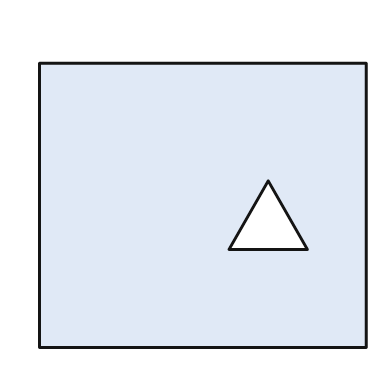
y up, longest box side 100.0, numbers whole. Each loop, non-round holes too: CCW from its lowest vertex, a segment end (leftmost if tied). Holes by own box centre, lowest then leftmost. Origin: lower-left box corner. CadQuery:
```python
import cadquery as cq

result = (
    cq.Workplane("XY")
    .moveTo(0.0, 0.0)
    .lineTo(100.0, 0.0)
    .lineTo(100.0, 87.0)
    .lineTo(0.0, 87.0)
    .close()
    .moveTo(58.0, 30.0)
    .lineTo(82.0, 30.0)
    .lineTo(70.0, 51.0)
    .close()
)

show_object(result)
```